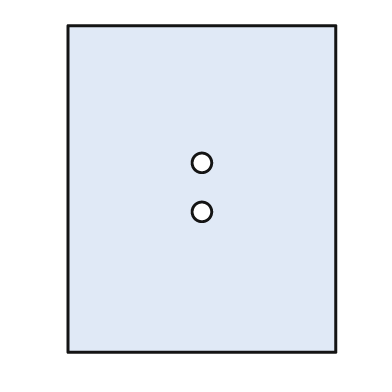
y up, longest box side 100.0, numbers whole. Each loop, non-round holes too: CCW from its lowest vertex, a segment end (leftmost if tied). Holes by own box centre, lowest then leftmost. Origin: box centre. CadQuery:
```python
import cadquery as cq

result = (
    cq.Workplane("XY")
    .moveTo(-41.0, -50.0)
    .lineTo(41.0, -50.0)
    .lineTo(41.0, 50.0)
    .lineTo(-41.0, 50.0)
    .close()
    .moveTo(0.0, -7.0)
    .circle(3.0)
    .moveTo(0.0, 8.0)
    .circle(3.0)
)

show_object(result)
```